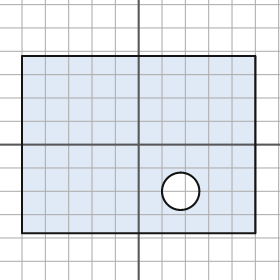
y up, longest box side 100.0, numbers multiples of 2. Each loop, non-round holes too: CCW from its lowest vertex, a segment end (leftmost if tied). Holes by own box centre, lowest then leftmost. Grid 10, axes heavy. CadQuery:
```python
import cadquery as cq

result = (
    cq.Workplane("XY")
    .moveTo(-50.0, -38.0)
    .lineTo(50.0, -38.0)
    .lineTo(50.0, 38.0)
    .lineTo(-50.0, 38.0)
    .close()
    .moveTo(18.0, -20.0)
    .circle(8.0)
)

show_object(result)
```